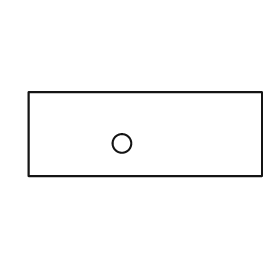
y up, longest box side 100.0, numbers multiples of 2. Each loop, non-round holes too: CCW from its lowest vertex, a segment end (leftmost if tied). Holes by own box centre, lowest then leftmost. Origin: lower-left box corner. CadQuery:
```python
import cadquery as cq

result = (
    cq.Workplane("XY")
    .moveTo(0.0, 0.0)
    .lineTo(100.0, 0.0)
    .lineTo(100.0, 36.0)
    .lineTo(0.0, 36.0)
    .close()
    .moveTo(40.0, 14.0)
    .circle(4.0)
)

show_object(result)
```